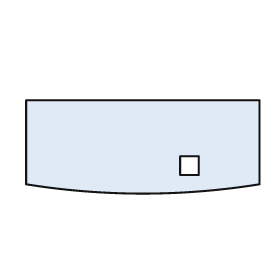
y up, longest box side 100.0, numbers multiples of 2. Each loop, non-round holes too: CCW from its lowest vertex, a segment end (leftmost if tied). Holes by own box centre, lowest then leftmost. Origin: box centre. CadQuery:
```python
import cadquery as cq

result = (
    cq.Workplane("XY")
    .moveTo(-50.0, -16.0)
    .threePointArc((0.0, -20.0), (50.0, -16.0))
    .lineTo(50.0, 20.0)
    .lineTo(-50.0, 20.0)
    .close()
    .moveTo(16.0, -12.0)
    .lineTo(24.0, -12.0)
    .lineTo(24.0, -4.0)
    .lineTo(16.0, -4.0)
    .close()
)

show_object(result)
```